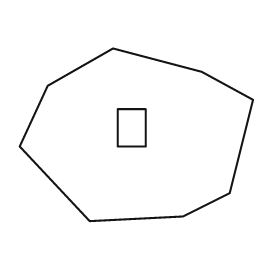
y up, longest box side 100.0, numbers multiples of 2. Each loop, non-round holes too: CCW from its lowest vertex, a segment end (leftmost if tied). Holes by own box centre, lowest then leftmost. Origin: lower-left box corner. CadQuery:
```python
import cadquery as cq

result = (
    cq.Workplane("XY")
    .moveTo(30.0, 0.0)
    .lineTo(70.0, 2.0)
    .lineTo(90.0, 12.0)
    .lineTo(100.0, 52.0)
    .lineTo(78.0, 64.0)
    .lineTo(40.0, 74.0)
    .lineTo(12.0, 58.0)
    .lineTo(0.0, 32.0)
    .close()
    .moveTo(42.0, 32.0)
    .lineTo(54.0, 32.0)
    .lineTo(54.0, 48.0)
    .lineTo(42.0, 48.0)
    .close()
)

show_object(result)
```